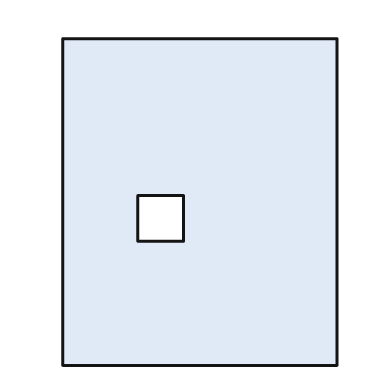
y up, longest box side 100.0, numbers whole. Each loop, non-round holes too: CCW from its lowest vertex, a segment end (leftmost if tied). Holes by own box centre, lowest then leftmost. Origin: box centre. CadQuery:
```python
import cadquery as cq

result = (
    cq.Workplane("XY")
    .moveTo(-42.0, -50.0)
    .lineTo(42.0, -50.0)
    .lineTo(42.0, 50.0)
    .lineTo(-42.0, 50.0)
    .close()
    .moveTo(-19.0, -12.0)
    .lineTo(-5.0, -12.0)
    .lineTo(-5.0, 2.0)
    .lineTo(-19.0, 2.0)
    .close()
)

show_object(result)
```